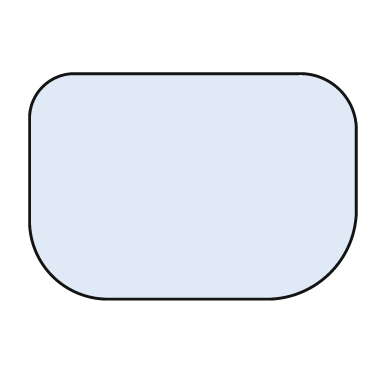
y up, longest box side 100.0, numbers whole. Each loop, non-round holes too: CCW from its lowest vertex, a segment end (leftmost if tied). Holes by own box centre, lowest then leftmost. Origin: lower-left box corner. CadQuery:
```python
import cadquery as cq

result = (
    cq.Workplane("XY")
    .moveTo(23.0, 0.0)
    .lineTo(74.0, 0.0)
    .threePointArc((92.0, 8.0), (100.0, 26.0))
    .lineTo(100.0, 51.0)
    .threePointArc((95.0, 64.0), (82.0, 69.0))
    .lineTo(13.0, 69.0)
    .threePointArc((4.0, 65.0), (0.0, 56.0))
    .lineTo(0.0, 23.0)
    .threePointArc((7.0, 7.0), (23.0, 0.0))
    .close()
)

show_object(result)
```